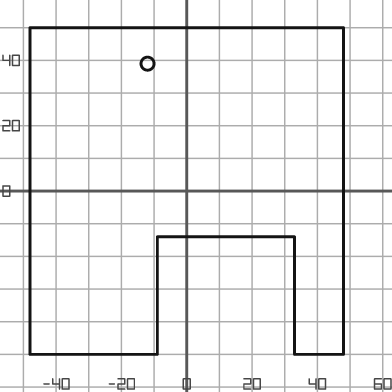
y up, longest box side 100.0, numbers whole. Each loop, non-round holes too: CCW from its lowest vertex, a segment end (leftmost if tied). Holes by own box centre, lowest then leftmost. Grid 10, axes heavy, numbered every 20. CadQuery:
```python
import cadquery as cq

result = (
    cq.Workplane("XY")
    .moveTo(-48.0, -50.0)
    .lineTo(-9.0, -50.0)
    .lineTo(-9.0, -14.0)
    .lineTo(33.0, -14.0)
    .lineTo(33.0, -50.0)
    .lineTo(48.0, -50.0)
    .lineTo(48.0, 50.0)
    .lineTo(-48.0, 50.0)
    .close()
    .moveTo(-12.0, 39.0)
    .circle(2.0)
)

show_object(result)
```